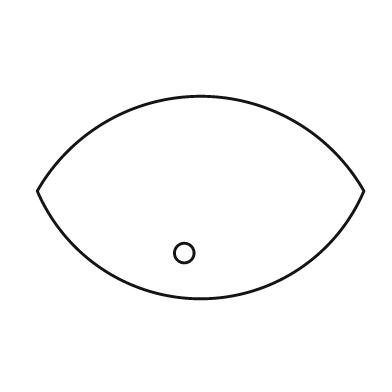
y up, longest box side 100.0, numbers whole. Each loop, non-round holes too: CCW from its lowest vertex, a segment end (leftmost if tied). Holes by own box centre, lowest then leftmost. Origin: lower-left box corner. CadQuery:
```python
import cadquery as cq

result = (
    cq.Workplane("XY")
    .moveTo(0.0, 33.0)
    .threePointArc((50.0, 0.0), (100.0, 33.0))
    .threePointArc((50.0, 62.0), (0.0, 33.0))
    .close()
    .moveTo(45.0, 14.0)
    .circle(3.0)
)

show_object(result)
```